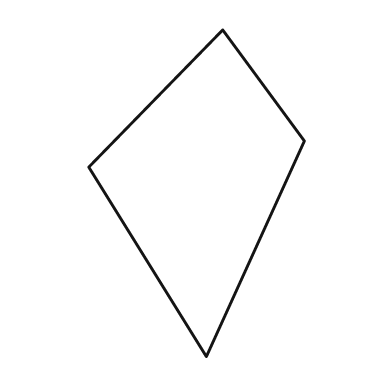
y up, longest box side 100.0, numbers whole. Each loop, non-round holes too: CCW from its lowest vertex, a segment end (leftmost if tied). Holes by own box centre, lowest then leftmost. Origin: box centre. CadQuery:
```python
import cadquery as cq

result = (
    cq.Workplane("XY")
    .moveTo(3.0, -50.0)
    .lineTo(33.0, 16.0)
    .lineTo(8.0, 50.0)
    .lineTo(-33.0, 8.0)
    .close()
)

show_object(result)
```